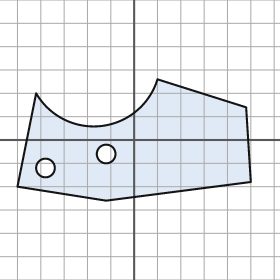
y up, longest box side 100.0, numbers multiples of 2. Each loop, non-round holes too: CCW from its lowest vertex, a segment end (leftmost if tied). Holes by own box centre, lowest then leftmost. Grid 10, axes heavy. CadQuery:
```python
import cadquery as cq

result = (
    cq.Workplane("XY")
    .moveTo(-12.0, -26.0)
    .lineTo(50.0, -18.0)
    .lineTo(48.0, 14.0)
    .lineTo(10.0, 26.0)
    .threePointArc((-14.0, 6.0), (-42.0, 20.0))
    .lineTo(-50.0, -20.0)
    .close()
    .moveTo(-38.0, -12.0)
    .circle(4.0)
    .moveTo(-12.0, -6.0)
    .circle(4.0)
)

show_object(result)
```